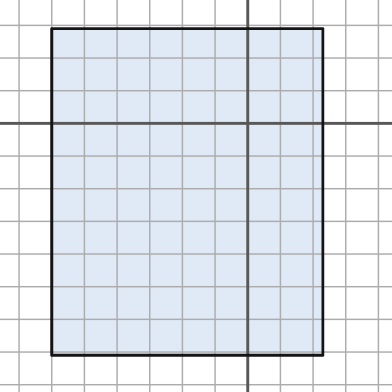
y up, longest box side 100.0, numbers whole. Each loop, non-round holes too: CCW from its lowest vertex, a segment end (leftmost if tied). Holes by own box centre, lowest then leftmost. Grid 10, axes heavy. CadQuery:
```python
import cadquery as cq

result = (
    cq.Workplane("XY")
    .moveTo(-60.0, -71.0)
    .lineTo(23.0, -71.0)
    .lineTo(23.0, 29.0)
    .lineTo(-60.0, 29.0)
    .close()
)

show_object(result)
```